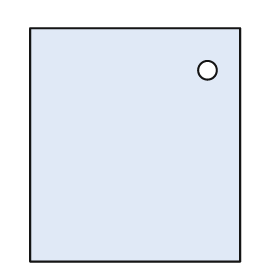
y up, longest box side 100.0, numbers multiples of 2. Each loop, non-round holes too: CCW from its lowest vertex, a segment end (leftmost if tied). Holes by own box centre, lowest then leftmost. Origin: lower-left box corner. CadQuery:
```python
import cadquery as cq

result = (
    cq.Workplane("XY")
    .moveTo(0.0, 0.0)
    .lineTo(90.0, 0.0)
    .lineTo(90.0, 100.0)
    .lineTo(0.0, 100.0)
    .close()
    .moveTo(76.0, 82.0)
    .circle(4.0)
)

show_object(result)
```